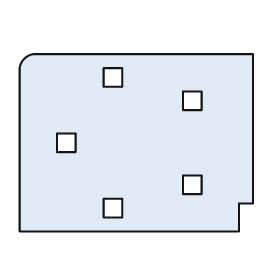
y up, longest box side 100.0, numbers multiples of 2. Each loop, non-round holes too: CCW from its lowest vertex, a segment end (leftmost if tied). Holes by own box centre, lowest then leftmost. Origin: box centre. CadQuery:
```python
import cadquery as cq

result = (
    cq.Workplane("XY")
    .moveTo(-50.0, -38.0)
    .lineTo(44.0, -38.0)
    .lineTo(44.0, -26.0)
    .lineTo(50.0, -26.0)
    .lineTo(50.0, 38.0)
    .lineTo(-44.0, 38.0)
    .threePointArc((-48.0, 36.0), (-50.0, 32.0))
    .close()
    .moveTo(-14.0, -32.0)
    .lineTo(-6.0, -32.0)
    .lineTo(-6.0, -24.0)
    .lineTo(-14.0, -24.0)
    .close()
    .moveTo(20.0, -22.0)
    .lineTo(28.0, -22.0)
    .lineTo(28.0, -14.0)
    .lineTo(20.0, -14.0)
    .close()
    .moveTo(-34.0, -4.0)
    .lineTo(-26.0, -4.0)
    .lineTo(-26.0, 4.0)
    .lineTo(-34.0, 4.0)
    .close()
    .moveTo(20.0, 14.0)
    .lineTo(28.0, 14.0)
    .lineTo(28.0, 22.0)
    .lineTo(20.0, 22.0)
    .close()
    .moveTo(-14.0, 24.0)
    .lineTo(-6.0, 24.0)
    .lineTo(-6.0, 32.0)
    .lineTo(-14.0, 32.0)
    .close()
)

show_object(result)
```